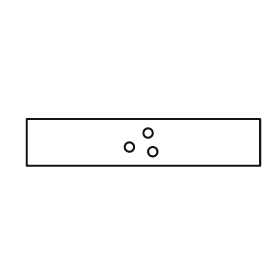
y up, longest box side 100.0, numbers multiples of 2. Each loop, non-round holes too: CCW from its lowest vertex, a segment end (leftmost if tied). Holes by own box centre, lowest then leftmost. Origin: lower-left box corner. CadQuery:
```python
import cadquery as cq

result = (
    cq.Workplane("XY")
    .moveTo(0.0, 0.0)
    .lineTo(100.0, 0.0)
    .lineTo(100.0, 20.0)
    .lineTo(0.0, 20.0)
    .close()
    .moveTo(54.0, 6.0)
    .circle(2.0)
    .moveTo(44.0, 8.0)
    .circle(2.0)
    .moveTo(52.0, 14.0)
    .circle(2.0)
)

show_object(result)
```